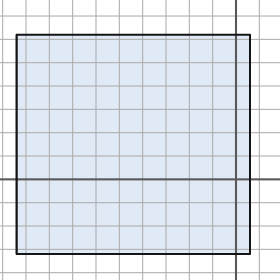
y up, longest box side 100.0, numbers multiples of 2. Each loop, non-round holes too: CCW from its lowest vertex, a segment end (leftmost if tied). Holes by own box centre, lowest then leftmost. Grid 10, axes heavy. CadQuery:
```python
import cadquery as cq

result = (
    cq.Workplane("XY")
    .moveTo(-94.0, -32.0)
    .lineTo(6.0, -32.0)
    .lineTo(6.0, 62.0)
    .lineTo(-94.0, 62.0)
    .close()
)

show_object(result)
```